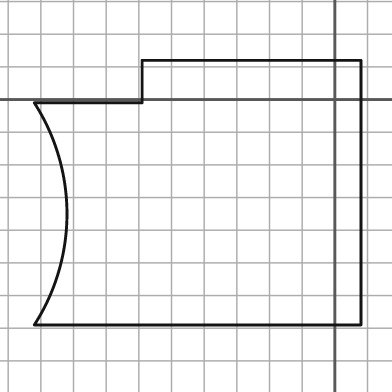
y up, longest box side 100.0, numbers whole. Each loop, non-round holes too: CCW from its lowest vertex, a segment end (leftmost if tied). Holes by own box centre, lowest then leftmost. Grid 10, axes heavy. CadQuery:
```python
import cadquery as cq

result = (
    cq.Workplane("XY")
    .moveTo(-92.0, -69.0)
    .lineTo(8.0, -69.0)
    .lineTo(8.0, 12.0)
    .lineTo(-59.0, 12.0)
    .lineTo(-59.0, -1.0)
    .lineTo(-92.0, -1.0)
    .threePointArc((-82.0, -35.0), (-92.0, -69.0))
    .close()
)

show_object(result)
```